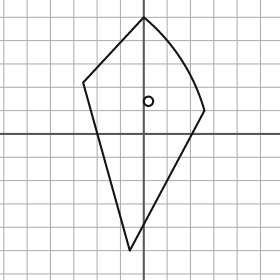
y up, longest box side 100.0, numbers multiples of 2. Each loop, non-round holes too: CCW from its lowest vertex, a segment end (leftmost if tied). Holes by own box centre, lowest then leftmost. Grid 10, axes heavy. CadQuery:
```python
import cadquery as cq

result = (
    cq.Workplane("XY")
    .moveTo(-6.0, -50.0)
    .lineTo(26.0, 10.0)
    .threePointArc((16.0, 32.0), (0.0, 50.0))
    .lineTo(-26.0, 22.0)
    .close()
    .moveTo(2.0, 14.0)
    .circle(2.0)
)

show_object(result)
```